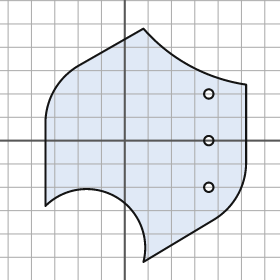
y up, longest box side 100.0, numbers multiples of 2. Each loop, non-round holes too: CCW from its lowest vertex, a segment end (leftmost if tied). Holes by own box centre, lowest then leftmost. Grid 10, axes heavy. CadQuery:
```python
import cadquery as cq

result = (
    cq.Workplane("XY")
    .moveTo(8.0, -52.0)
    .lineTo(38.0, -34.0)
    .threePointArc((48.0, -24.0), (52.0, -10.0))
    .lineTo(52.0, 24.0)
    .threePointArc((28.0, 32.0), (8.0, 48.0))
    .lineTo(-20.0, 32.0)
    .threePointArc((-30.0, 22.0), (-34.0, 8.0))
    .lineTo(-34.0, -28.0)
    .threePointArc((-4.0, -24.0), (8.0, -52.0))
    .close()
    .moveTo(36.0, -20.0)
    .circle(2.0)
    .moveTo(36.0, 0.0)
    .circle(2.0)
    .moveTo(36.0, 20.0)
    .circle(2.0)
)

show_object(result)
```